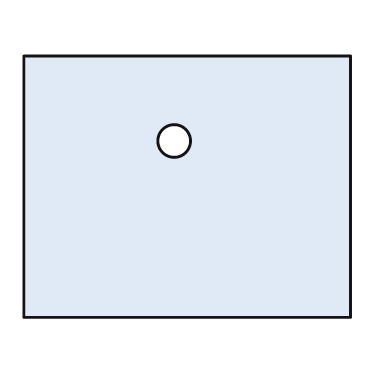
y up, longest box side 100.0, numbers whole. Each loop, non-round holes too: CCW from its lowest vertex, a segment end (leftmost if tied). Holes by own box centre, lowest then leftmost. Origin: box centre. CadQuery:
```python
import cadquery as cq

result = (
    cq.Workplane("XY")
    .moveTo(-50.0, -40.0)
    .lineTo(50.0, -40.0)
    .lineTo(50.0, 40.0)
    .lineTo(-50.0, 40.0)
    .close()
    .moveTo(-4.0, 14.0)
    .circle(5.0)
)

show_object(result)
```